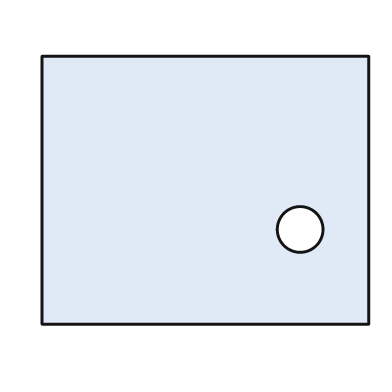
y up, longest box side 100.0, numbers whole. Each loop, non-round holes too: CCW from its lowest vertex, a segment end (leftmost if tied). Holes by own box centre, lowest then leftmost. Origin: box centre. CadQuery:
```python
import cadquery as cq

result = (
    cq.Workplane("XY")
    .moveTo(-50.0, -41.0)
    .lineTo(50.0, -41.0)
    .lineTo(50.0, 41.0)
    .lineTo(-50.0, 41.0)
    .close()
    .moveTo(29.0, -12.0)
    .circle(7.0)
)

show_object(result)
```